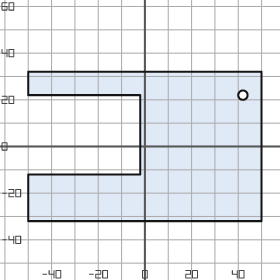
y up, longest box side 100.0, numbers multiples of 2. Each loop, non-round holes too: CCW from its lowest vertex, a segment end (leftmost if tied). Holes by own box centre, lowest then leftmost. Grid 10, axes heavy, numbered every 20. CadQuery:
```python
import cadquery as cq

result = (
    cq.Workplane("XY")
    .moveTo(-50.0, -32.0)
    .lineTo(50.0, -32.0)
    .lineTo(50.0, 32.0)
    .lineTo(-50.0, 32.0)
    .lineTo(-50.0, 22.0)
    .lineTo(-2.0, 22.0)
    .lineTo(-2.0, -12.0)
    .lineTo(-50.0, -12.0)
    .close()
    .moveTo(42.0, 22.0)
    .circle(2.0)
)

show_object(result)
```